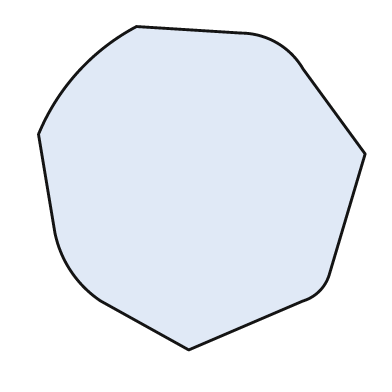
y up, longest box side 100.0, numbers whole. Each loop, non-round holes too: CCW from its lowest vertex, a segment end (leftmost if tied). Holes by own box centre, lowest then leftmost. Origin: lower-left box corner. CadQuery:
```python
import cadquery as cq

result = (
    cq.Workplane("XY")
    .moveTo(46.0, 0.0)
    .lineTo(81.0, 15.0)
    .threePointArc((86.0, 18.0), (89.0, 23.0))
    .lineTo(100.0, 60.0)
    .lineTo(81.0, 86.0)
    .threePointArc((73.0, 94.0), (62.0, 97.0))
    .lineTo(30.0, 99.0)
    .threePointArc((12.0, 85.0), (0.0, 66.0))
    .lineTo(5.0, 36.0)
    .threePointArc((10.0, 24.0), (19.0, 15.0))
    .close()
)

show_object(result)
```